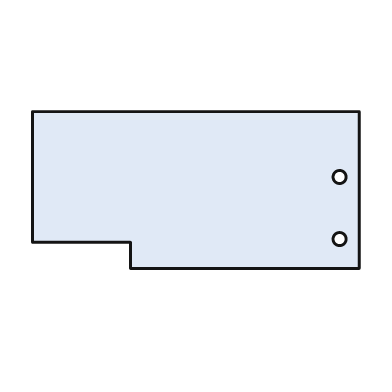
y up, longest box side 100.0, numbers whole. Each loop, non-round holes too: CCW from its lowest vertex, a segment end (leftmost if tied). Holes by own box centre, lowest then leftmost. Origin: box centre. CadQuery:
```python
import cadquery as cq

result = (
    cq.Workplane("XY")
    .moveTo(-20.0, -24.0)
    .lineTo(50.0, -24.0)
    .lineTo(50.0, 24.0)
    .lineTo(-50.0, 24.0)
    .lineTo(-50.0, -16.0)
    .lineTo(-20.0, -16.0)
    .close()
    .moveTo(44.0, -15.0)
    .circle(2.0)
    .moveTo(44.0, 4.0)
    .circle(2.0)
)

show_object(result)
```